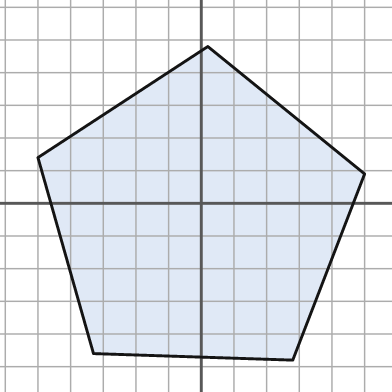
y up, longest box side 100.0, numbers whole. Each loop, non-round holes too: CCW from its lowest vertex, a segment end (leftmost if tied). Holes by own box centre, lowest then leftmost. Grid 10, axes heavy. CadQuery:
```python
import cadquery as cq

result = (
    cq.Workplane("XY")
    .moveTo(28.0, -48.0)
    .lineTo(50.0, 9.0)
    .lineTo(2.0, 48.0)
    .lineTo(-50.0, 14.0)
    .lineTo(-33.0, -46.0)
    .close()
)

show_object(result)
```